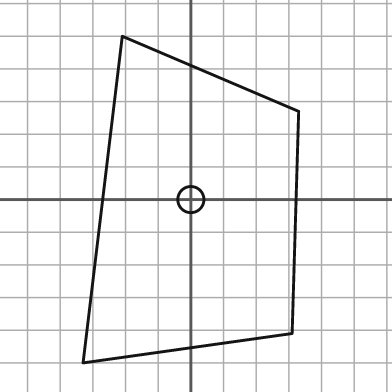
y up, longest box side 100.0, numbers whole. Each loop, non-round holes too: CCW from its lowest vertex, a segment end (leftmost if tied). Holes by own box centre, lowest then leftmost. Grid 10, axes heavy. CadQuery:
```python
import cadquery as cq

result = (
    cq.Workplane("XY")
    .moveTo(-33.0, -50.0)
    .lineTo(31.0, -41.0)
    .lineTo(33.0, 27.0)
    .lineTo(-21.0, 50.0)
    .close()
    .moveTo(0.0, 0.0)
    .circle(4.0)
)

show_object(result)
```